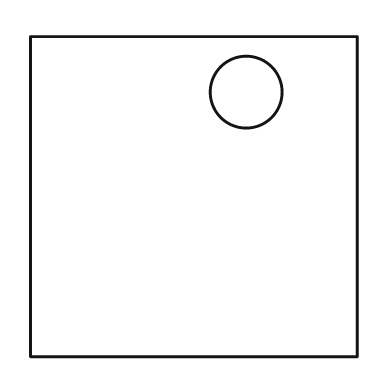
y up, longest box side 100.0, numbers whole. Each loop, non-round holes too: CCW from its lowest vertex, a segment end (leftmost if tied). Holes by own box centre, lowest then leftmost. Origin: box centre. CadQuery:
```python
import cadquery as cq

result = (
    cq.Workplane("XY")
    .moveTo(-50.0, -49.0)
    .lineTo(50.0, -49.0)
    .lineTo(50.0, 49.0)
    .lineTo(-50.0, 49.0)
    .close()
    .moveTo(16.0, 32.0)
    .circle(11.0)
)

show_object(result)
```